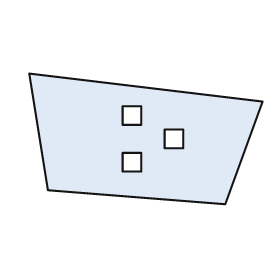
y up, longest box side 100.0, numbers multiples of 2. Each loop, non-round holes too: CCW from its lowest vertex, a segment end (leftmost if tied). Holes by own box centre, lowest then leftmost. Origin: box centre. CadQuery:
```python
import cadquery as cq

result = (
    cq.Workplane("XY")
    .moveTo(34.0, -28.0)
    .lineTo(50.0, 16.0)
    .lineTo(-50.0, 28.0)
    .lineTo(-42.0, -22.0)
    .close()
    .moveTo(-10.0, -14.0)
    .lineTo(-2.0, -14.0)
    .lineTo(-2.0, -6.0)
    .lineTo(-10.0, -6.0)
    .close()
    .moveTo(8.0, -4.0)
    .lineTo(16.0, -4.0)
    .lineTo(16.0, 4.0)
    .lineTo(8.0, 4.0)
    .close()
    .moveTo(-10.0, 6.0)
    .lineTo(-2.0, 6.0)
    .lineTo(-2.0, 14.0)
    .lineTo(-10.0, 14.0)
    .close()
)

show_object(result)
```